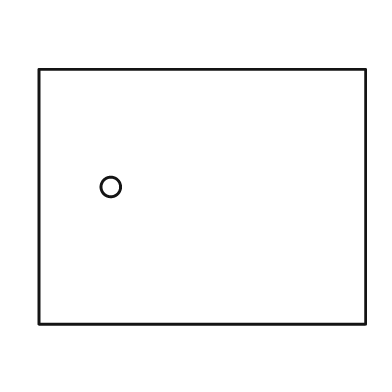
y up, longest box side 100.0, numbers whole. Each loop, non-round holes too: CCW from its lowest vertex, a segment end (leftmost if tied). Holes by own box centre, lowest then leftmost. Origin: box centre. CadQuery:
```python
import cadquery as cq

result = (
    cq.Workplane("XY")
    .moveTo(-50.0, -39.0)
    .lineTo(50.0, -39.0)
    .lineTo(50.0, 39.0)
    .lineTo(-50.0, 39.0)
    .close()
    .moveTo(-28.0, 3.0)
    .circle(3.0)
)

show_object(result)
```